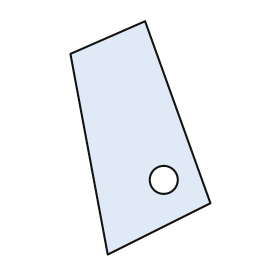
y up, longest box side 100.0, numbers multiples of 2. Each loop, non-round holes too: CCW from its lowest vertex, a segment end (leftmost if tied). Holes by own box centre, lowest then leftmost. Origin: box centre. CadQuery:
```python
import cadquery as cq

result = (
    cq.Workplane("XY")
    .moveTo(-14.0, -50.0)
    .lineTo(30.0, -28.0)
    .lineTo(2.0, 50.0)
    .lineTo(-30.0, 36.0)
    .close()
    .moveTo(10.0, -18.0)
    .circle(6.0)
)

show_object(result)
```